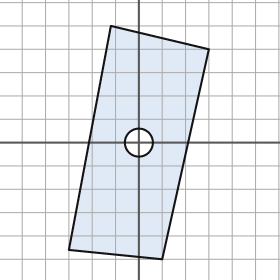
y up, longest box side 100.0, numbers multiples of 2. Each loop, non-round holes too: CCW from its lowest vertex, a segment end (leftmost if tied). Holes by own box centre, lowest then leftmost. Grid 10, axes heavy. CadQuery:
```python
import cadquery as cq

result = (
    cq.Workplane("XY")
    .moveTo(10.0, -50.0)
    .lineTo(30.0, 40.0)
    .lineTo(-12.0, 50.0)
    .lineTo(-30.0, -46.0)
    .close()
    .moveTo(0.0, 0.0)
    .circle(6.0)
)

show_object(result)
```